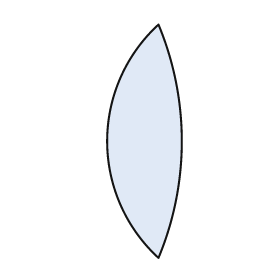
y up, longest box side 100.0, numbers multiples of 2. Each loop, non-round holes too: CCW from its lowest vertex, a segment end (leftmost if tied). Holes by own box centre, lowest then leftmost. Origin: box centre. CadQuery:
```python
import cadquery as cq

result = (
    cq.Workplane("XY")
    .moveTo(6.0, -50.0)
    .threePointArc((16.0, 0.0), (6.0, 50.0))
    .threePointArc((-16.0, 0.0), (6.0, -50.0))
    .close()
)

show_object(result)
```